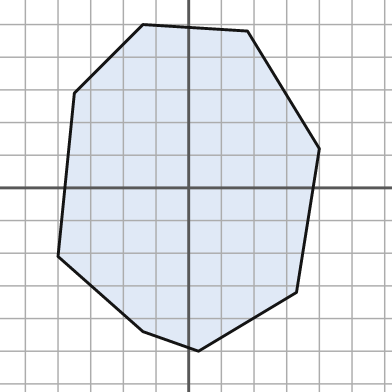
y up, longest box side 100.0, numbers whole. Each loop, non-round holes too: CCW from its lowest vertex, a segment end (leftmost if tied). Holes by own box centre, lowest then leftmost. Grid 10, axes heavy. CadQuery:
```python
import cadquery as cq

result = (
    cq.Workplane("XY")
    .moveTo(3.0, -50.0)
    .lineTo(33.0, -32.0)
    .lineTo(40.0, 12.0)
    .lineTo(18.0, 48.0)
    .lineTo(-14.0, 50.0)
    .lineTo(-35.0, 29.0)
    .lineTo(-40.0, -21.0)
    .lineTo(-14.0, -44.0)
    .close()
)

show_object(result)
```